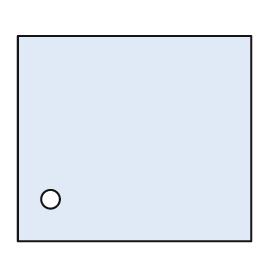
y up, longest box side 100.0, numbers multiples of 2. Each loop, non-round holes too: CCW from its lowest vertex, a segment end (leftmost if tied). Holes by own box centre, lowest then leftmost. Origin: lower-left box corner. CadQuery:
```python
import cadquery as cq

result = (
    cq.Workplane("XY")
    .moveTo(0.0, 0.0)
    .lineTo(100.0, 0.0)
    .lineTo(100.0, 88.0)
    .lineTo(0.0, 88.0)
    .close()
    .moveTo(14.0, 18.0)
    .circle(4.0)
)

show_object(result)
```